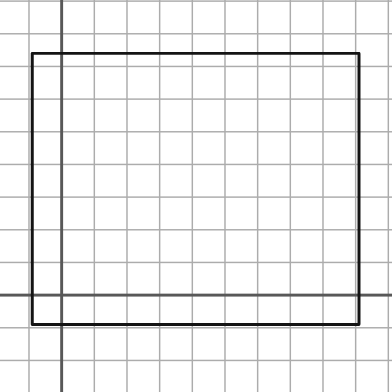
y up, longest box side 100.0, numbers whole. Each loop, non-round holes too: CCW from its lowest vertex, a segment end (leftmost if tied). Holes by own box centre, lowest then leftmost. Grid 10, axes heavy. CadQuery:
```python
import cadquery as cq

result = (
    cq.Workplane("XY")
    .moveTo(-9.0, -9.0)
    .lineTo(91.0, -9.0)
    .lineTo(91.0, 74.0)
    .lineTo(-9.0, 74.0)
    .close()
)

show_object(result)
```